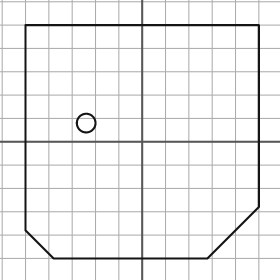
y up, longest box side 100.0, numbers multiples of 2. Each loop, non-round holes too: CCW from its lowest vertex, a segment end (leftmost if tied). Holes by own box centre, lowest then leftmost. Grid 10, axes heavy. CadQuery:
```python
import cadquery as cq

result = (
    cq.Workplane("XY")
    .moveTo(-38.0, -50.0)
    .lineTo(28.0, -50.0)
    .lineTo(50.0, -28.0)
    .lineTo(50.0, 50.0)
    .lineTo(-50.0, 50.0)
    .lineTo(-50.0, -38.0)
    .close()
    .moveTo(-24.0, 8.0)
    .circle(4.0)
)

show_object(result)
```